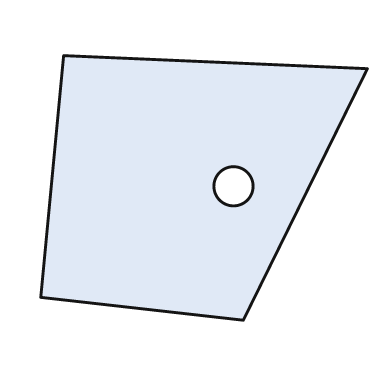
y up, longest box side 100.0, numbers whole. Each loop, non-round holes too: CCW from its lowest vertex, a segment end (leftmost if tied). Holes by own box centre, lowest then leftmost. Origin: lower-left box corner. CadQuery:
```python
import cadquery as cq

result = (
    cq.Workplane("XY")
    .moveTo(62.0, 0.0)
    .lineTo(100.0, 77.0)
    .lineTo(7.0, 81.0)
    .lineTo(0.0, 7.0)
    .close()
    .moveTo(59.0, 41.0)
    .circle(6.0)
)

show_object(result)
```